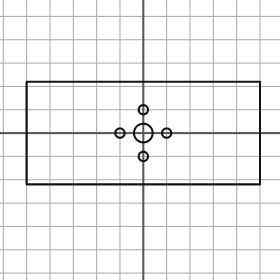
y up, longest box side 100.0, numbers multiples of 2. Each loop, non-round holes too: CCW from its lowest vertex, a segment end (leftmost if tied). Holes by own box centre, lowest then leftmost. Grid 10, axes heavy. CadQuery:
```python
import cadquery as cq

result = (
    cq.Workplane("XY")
    .moveTo(-50.0, -22.0)
    .lineTo(50.0, -22.0)
    .lineTo(50.0, 22.0)
    .lineTo(-50.0, 22.0)
    .close()
    .moveTo(0.0, -10.0)
    .circle(2.0)
    .moveTo(-10.0, 0.0)
    .circle(2.0)
    .moveTo(0.0, 0.0)
    .circle(4.0)
    .moveTo(10.0, 0.0)
    .circle(2.0)
    .moveTo(0.0, 10.0)
    .circle(2.0)
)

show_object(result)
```